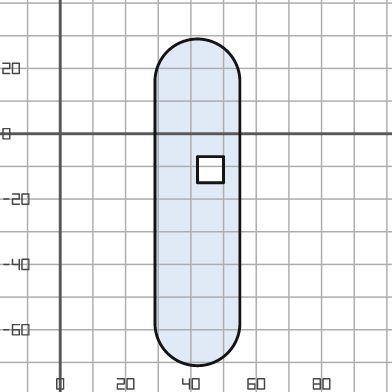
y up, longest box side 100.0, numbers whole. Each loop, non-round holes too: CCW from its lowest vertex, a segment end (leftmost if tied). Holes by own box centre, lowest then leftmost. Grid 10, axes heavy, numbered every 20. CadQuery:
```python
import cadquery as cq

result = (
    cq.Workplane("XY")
    .moveTo(29.0, -58.0)
    .threePointArc((42.0, -71.0), (55.0, -58.0))
    .lineTo(55.0, 16.0)
    .threePointArc((42.0, 29.0), (29.0, 16.0))
    .close()
    .moveTo(42.0, -15.0)
    .lineTo(50.0, -15.0)
    .lineTo(50.0, -7.0)
    .lineTo(42.0, -7.0)
    .close()
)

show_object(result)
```